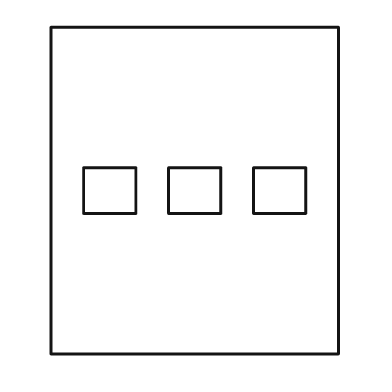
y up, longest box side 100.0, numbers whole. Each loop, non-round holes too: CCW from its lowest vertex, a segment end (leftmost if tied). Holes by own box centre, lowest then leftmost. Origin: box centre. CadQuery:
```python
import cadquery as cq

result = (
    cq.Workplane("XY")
    .moveTo(-44.0, -50.0)
    .lineTo(44.0, -50.0)
    .lineTo(44.0, 50.0)
    .lineTo(-44.0, 50.0)
    .close()
    .moveTo(-34.0, -7.0)
    .lineTo(-18.0, -7.0)
    .lineTo(-18.0, 7.0)
    .lineTo(-34.0, 7.0)
    .close()
    .moveTo(-8.0, -7.0)
    .lineTo(8.0, -7.0)
    .lineTo(8.0, 7.0)
    .lineTo(-8.0, 7.0)
    .close()
    .moveTo(18.0, -7.0)
    .lineTo(34.0, -7.0)
    .lineTo(34.0, 7.0)
    .lineTo(18.0, 7.0)
    .close()
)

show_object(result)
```